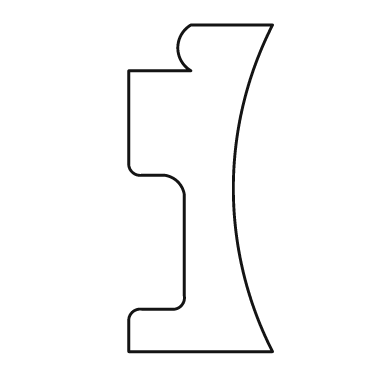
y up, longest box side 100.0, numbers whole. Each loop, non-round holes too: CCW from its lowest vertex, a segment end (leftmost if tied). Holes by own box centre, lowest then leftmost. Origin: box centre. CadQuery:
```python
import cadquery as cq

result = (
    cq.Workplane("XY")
    .moveTo(-22.0, -50.0)
    .lineTo(22.0, -50.0)
    .threePointArc((10.0, 0.0), (22.0, 50.0))
    .lineTo(-3.0, 50.0)
    .threePointArc((-7.0, 43.0), (-3.0, 36.0))
    .lineTo(-22.0, 36.0)
    .lineTo(-22.0, 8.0)
    .threePointArc((-21.0, 5.0), (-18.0, 4.0))
    .lineTo(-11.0, 4.0)
    .threePointArc((-7.0, 2.0), (-5.0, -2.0))
    .lineTo(-5.0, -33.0)
    .threePointArc((-6.0, -36.0), (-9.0, -37.0))
    .lineTo(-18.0, -37.0)
    .threePointArc((-21.0, -38.0), (-22.0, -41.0))
    .close()
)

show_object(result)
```